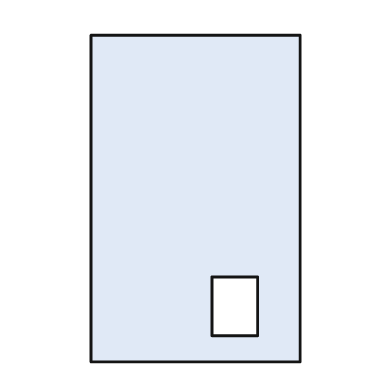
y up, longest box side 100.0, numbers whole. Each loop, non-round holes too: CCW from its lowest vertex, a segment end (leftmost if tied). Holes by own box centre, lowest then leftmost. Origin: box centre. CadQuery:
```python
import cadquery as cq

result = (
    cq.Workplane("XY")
    .moveTo(-32.0, -50.0)
    .lineTo(32.0, -50.0)
    .lineTo(32.0, 50.0)
    .lineTo(-32.0, 50.0)
    .close()
    .moveTo(5.0, -42.0)
    .lineTo(19.0, -42.0)
    .lineTo(19.0, -24.0)
    .lineTo(5.0, -24.0)
    .close()
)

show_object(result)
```